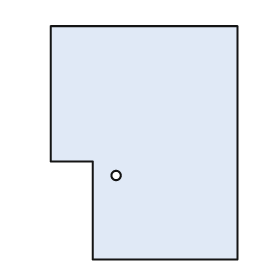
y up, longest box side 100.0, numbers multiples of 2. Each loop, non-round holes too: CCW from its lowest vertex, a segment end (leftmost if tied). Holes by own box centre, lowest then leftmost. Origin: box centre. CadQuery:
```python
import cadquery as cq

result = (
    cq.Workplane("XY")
    .moveTo(-22.0, -50.0)
    .lineTo(40.0, -50.0)
    .lineTo(40.0, 50.0)
    .lineTo(-40.0, 50.0)
    .lineTo(-40.0, -8.0)
    .lineTo(-22.0, -8.0)
    .close()
    .moveTo(-12.0, -14.0)
    .circle(2.0)
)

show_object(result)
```